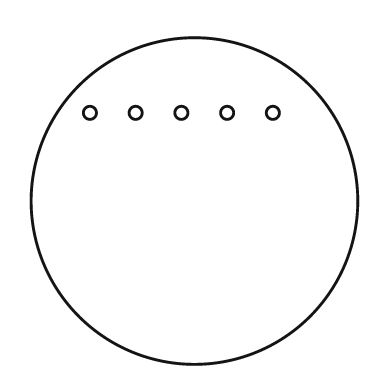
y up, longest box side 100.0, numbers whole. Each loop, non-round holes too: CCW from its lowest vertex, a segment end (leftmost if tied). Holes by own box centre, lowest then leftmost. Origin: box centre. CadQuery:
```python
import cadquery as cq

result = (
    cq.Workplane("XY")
    .moveTo(0.0, 0.0)
    .circle(50.0)
    .moveTo(-32.0, 27.0)
    .circle(2.0)
    .moveTo(-18.0, 27.0)
    .circle(2.0)
    .moveTo(-4.0, 27.0)
    .circle(2.0)
    .moveTo(10.0, 27.0)
    .circle(2.0)
    .moveTo(24.0, 27.0)
    .circle(2.0)
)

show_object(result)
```